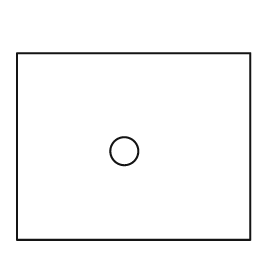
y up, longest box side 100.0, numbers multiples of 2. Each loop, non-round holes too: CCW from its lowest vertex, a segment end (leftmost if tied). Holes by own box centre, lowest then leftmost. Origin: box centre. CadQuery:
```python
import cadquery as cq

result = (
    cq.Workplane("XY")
    .moveTo(-50.0, -40.0)
    .lineTo(50.0, -40.0)
    .lineTo(50.0, 40.0)
    .lineTo(-50.0, 40.0)
    .close()
    .moveTo(-4.0, -2.0)
    .circle(6.0)
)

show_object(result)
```